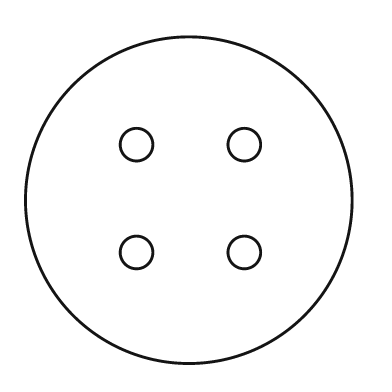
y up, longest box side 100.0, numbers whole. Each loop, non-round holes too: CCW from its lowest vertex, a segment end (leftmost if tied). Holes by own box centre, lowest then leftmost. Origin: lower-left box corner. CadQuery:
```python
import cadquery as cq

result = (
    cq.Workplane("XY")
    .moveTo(50.0, 50.0)
    .circle(50.0)
    .moveTo(34.0, 34.0)
    .circle(5.0)
    .moveTo(67.0, 34.0)
    .circle(5.0)
    .moveTo(34.0, 67.0)
    .circle(5.0)
    .moveTo(67.0, 67.0)
    .circle(5.0)
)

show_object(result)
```